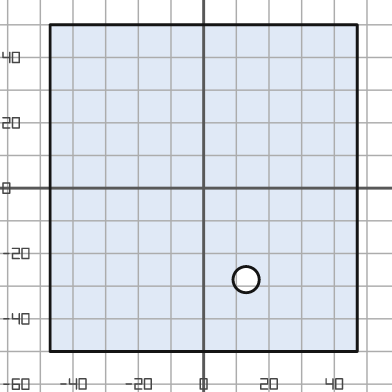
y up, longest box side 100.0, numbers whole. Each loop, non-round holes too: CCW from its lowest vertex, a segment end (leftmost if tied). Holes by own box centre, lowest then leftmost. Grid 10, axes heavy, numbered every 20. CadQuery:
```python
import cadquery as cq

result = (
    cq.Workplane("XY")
    .moveTo(-47.0, -50.0)
    .lineTo(47.0, -50.0)
    .lineTo(47.0, 50.0)
    .lineTo(-47.0, 50.0)
    .close()
    .moveTo(13.0, -28.0)
    .circle(4.0)
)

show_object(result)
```